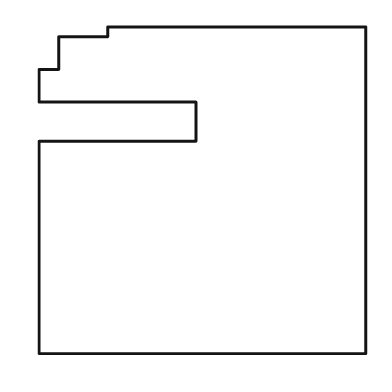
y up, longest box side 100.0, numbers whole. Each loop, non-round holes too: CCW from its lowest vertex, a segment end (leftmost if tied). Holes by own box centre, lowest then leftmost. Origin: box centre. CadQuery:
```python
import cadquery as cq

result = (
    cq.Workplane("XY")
    .moveTo(-50.0, -50.0)
    .lineTo(50.0, -50.0)
    .lineTo(50.0, 50.0)
    .lineTo(-29.0, 50.0)
    .lineTo(-29.0, 47.0)
    .lineTo(-44.0, 47.0)
    .lineTo(-44.0, 37.0)
    .lineTo(-50.0, 37.0)
    .lineTo(-50.0, 27.0)
    .lineTo(-2.0, 27.0)
    .lineTo(-2.0, 15.0)
    .lineTo(-50.0, 15.0)
    .close()
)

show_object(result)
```